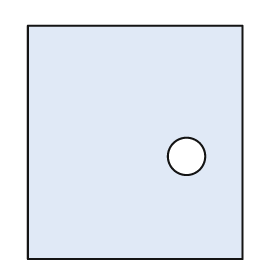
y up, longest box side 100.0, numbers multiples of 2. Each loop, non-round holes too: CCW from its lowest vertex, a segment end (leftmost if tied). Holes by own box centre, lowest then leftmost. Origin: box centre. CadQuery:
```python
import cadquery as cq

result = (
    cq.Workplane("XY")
    .moveTo(-46.0, -50.0)
    .lineTo(46.0, -50.0)
    .lineTo(46.0, 50.0)
    .lineTo(-46.0, 50.0)
    .close()
    .moveTo(22.0, -6.0)
    .circle(8.0)
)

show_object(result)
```